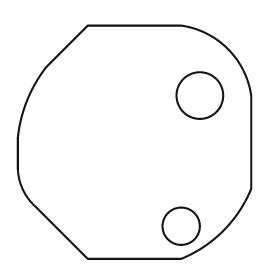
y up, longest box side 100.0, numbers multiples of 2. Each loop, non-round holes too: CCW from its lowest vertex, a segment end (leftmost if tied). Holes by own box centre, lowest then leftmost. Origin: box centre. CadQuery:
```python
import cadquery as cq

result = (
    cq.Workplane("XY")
    .moveTo(-20.0, -50.0)
    .lineTo(20.0, -50.0)
    .threePointArc((38.0, -38.0), (50.0, -20.0))
    .lineTo(50.0, 20.0)
    .threePointArc((40.0, 40.0), (20.0, 50.0))
    .lineTo(-20.0, 50.0)
    .lineTo(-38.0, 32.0)
    .threePointArc((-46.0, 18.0), (-50.0, 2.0))
    .lineTo(-50.0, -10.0)
    .threePointArc((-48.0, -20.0), (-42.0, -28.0))
    .close()
    .moveTo(20.0, -36.0)
    .circle(8.0)
    .moveTo(28.0, 20.0)
    .circle(10.0)
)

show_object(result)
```